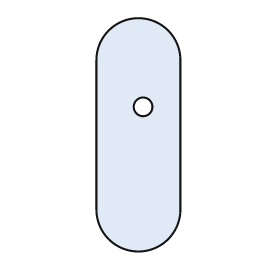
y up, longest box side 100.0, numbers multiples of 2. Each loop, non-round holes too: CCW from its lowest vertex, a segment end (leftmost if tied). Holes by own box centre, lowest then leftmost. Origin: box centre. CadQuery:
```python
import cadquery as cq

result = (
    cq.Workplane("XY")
    .moveTo(-18.0, -32.0)
    .threePointArc((0.0, -50.0), (18.0, -32.0))
    .lineTo(18.0, 32.0)
    .threePointArc((0.0, 50.0), (-18.0, 32.0))
    .close()
    .moveTo(2.0, 12.0)
    .circle(4.0)
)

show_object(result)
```